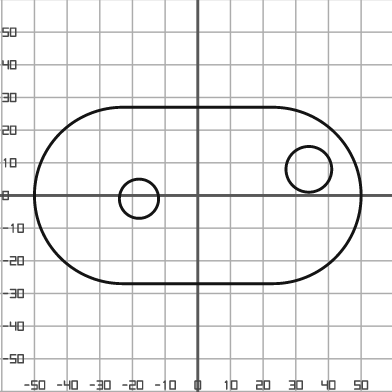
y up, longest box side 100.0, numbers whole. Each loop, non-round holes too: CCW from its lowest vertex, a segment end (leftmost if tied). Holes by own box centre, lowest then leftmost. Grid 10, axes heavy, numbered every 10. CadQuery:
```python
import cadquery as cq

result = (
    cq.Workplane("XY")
    .moveTo(-23.0, -27.0)
    .lineTo(23.0, -27.0)
    .threePointArc((50.0, 0.0), (23.0, 27.0))
    .lineTo(-23.0, 27.0)
    .threePointArc((-50.0, 0.0), (-23.0, -27.0))
    .close()
    .moveTo(-18.0, -1.0)
    .circle(6.0)
    .moveTo(34.0, 8.0)
    .circle(7.0)
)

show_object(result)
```